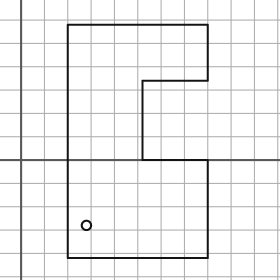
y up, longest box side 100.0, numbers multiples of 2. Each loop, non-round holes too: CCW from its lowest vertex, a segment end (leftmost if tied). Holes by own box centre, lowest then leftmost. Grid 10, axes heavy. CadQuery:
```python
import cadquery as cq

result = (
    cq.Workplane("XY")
    .moveTo(20.0, -42.0)
    .lineTo(80.0, -42.0)
    .lineTo(80.0, 0.0)
    .lineTo(52.0, 0.0)
    .lineTo(52.0, 34.0)
    .lineTo(80.0, 34.0)
    .lineTo(80.0, 58.0)
    .lineTo(20.0, 58.0)
    .close()
    .moveTo(28.0, -28.0)
    .circle(2.0)
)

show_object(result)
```